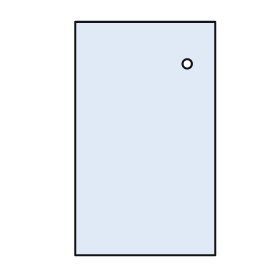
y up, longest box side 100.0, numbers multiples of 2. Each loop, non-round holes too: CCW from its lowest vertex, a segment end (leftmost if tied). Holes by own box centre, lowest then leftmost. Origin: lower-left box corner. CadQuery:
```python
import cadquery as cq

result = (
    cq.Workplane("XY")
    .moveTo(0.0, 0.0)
    .lineTo(60.0, 0.0)
    .lineTo(60.0, 100.0)
    .lineTo(0.0, 100.0)
    .close()
    .moveTo(48.0, 82.0)
    .circle(2.0)
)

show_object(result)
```